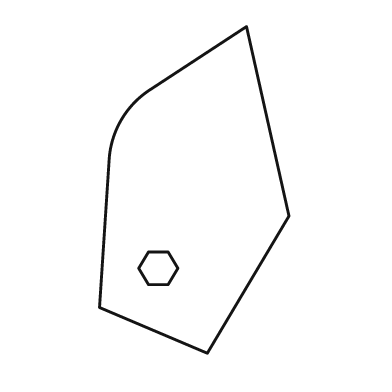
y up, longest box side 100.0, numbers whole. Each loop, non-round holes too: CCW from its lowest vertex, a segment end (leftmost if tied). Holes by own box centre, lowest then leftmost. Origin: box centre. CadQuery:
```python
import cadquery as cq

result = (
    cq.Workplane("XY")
    .moveTo(4.0, -50.0)
    .lineTo(29.0, -8.0)
    .lineTo(16.0, 50.0)
    .lineTo(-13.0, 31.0)
    .threePointArc((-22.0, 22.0), (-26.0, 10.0))
    .lineTo(-29.0, -36.0)
    .close()
    .moveTo(-14.0, -29.0)
    .lineTo(-8.0, -29.0)
    .lineTo(-5.0, -24.0)
    .lineTo(-8.0, -19.0)
    .lineTo(-14.0, -19.0)
    .lineTo(-17.0, -24.0)
    .close()
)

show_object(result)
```